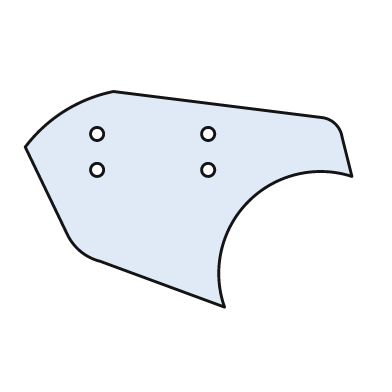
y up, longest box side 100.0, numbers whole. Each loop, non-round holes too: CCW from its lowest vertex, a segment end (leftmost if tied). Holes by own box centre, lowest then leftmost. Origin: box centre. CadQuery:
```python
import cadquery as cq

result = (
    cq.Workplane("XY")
    .moveTo(11.0, -33.0)
    .threePointArc((18.0, -1.0), (50.0, 7.0))
    .lineTo(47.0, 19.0)
    .threePointArc((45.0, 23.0), (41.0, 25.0))
    .lineTo(-23.0, 33.0)
    .threePointArc((-38.0, 27.0), (-50.0, 16.0))
    .lineTo(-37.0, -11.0)
    .threePointArc((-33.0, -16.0), (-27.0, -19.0))
    .close()
    .moveTo(-28.0, 9.0)
    .circle(2.0)
    .moveTo(6.0, 9.0)
    .circle(2.0)
    .moveTo(-28.0, 20.0)
    .circle(2.0)
    .moveTo(6.0, 20.0)
    .circle(2.0)
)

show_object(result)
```